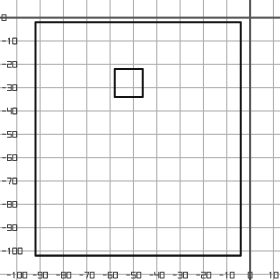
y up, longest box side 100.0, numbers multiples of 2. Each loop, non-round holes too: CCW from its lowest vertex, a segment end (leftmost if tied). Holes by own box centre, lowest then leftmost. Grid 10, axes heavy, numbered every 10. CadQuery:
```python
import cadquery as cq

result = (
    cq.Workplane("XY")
    .moveTo(-92.0, -102.0)
    .lineTo(-4.0, -102.0)
    .lineTo(-4.0, -2.0)
    .lineTo(-92.0, -2.0)
    .close()
    .moveTo(-58.0, -34.0)
    .lineTo(-46.0, -34.0)
    .lineTo(-46.0, -22.0)
    .lineTo(-58.0, -22.0)
    .close()
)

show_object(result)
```